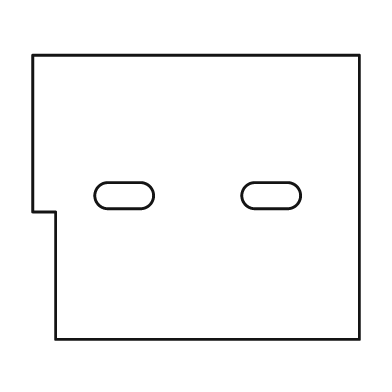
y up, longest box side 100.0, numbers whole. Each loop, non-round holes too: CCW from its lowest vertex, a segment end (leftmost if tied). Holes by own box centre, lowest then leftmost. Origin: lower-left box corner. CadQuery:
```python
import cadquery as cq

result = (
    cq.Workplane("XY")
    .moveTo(7.0, 0.0)
    .lineTo(100.0, 0.0)
    .lineTo(100.0, 87.0)
    .lineTo(0.0, 87.0)
    .lineTo(0.0, 39.0)
    .lineTo(7.0, 39.0)
    .close()
    .moveTo(23.0, 40.0)
    .lineTo(33.0, 40.0)
    .threePointArc((37.0, 44.0), (33.0, 48.0))
    .lineTo(23.0, 48.0)
    .threePointArc((19.0, 44.0), (23.0, 40.0))
    .close()
    .moveTo(68.0, 40.0)
    .lineTo(78.0, 40.0)
    .threePointArc((82.0, 44.0), (78.0, 48.0))
    .lineTo(68.0, 48.0)
    .threePointArc((64.0, 44.0), (68.0, 40.0))
    .close()
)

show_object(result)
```